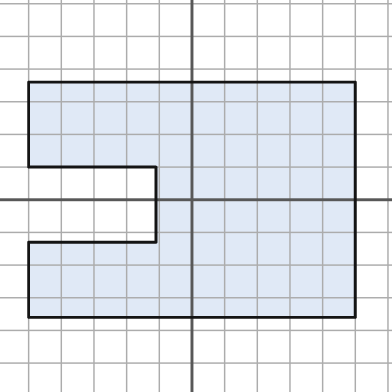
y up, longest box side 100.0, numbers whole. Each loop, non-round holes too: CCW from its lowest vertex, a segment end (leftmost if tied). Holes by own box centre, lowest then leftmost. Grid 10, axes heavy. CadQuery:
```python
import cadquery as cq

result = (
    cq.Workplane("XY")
    .moveTo(-50.0, -36.0)
    .lineTo(50.0, -36.0)
    .lineTo(50.0, 36.0)
    .lineTo(-50.0, 36.0)
    .lineTo(-50.0, 10.0)
    .lineTo(-11.0, 10.0)
    .lineTo(-11.0, -13.0)
    .lineTo(-50.0, -13.0)
    .close()
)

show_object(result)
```